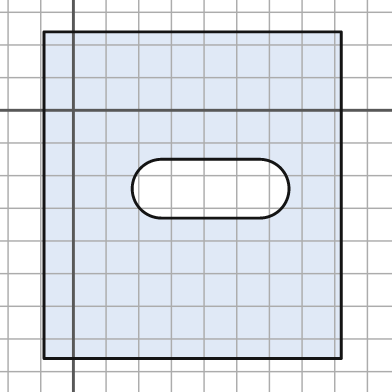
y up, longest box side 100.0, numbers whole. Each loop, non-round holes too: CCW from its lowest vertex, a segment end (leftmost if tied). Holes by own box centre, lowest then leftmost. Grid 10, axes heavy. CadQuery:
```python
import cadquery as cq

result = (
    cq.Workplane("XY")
    .moveTo(-9.0, -76.0)
    .lineTo(82.0, -76.0)
    .lineTo(82.0, 24.0)
    .lineTo(-9.0, 24.0)
    .close()
    .moveTo(27.0, -33.0)
    .lineTo(57.0, -33.0)
    .threePointArc((66.0, -24.0), (57.0, -15.0))
    .lineTo(27.0, -15.0)
    .threePointArc((18.0, -24.0), (27.0, -33.0))
    .close()
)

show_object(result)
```